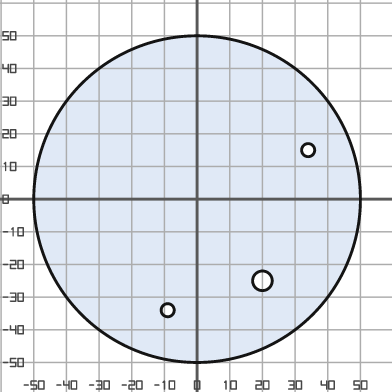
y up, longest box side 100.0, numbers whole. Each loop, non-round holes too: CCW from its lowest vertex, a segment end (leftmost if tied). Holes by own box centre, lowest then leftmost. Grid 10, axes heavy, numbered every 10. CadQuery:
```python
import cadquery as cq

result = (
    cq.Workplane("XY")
    .moveTo(0.0, 0.0)
    .circle(50.0)
    .moveTo(-9.0, -34.0)
    .circle(2.0)
    .moveTo(20.0, -25.0)
    .circle(3.0)
    .moveTo(34.0, 15.0)
    .circle(2.0)
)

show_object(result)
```